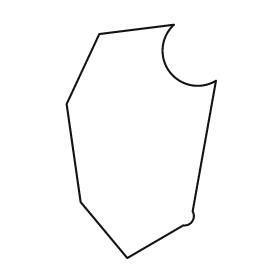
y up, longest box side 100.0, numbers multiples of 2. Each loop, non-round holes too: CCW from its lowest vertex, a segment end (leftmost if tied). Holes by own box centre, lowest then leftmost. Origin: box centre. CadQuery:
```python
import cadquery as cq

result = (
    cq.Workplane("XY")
    .moveTo(-6.0, -50.0)
    .lineTo(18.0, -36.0)
    .threePointArc((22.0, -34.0), (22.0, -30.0))
    .lineTo(32.0, 26.0)
    .threePointArc((12.0, 30.0), (14.0, 50.0))
    .lineTo(-18.0, 46.0)
    .lineTo(-32.0, 16.0)
    .lineTo(-26.0, -26.0)
    .close()
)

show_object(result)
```